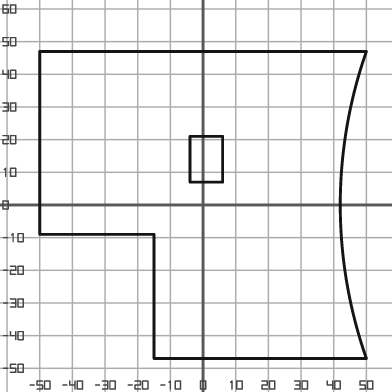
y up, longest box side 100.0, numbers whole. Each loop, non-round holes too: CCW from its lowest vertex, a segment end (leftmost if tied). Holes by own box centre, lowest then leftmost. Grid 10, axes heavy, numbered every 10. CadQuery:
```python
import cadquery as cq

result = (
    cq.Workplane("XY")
    .moveTo(-15.0, -47.0)
    .lineTo(50.0, -47.0)
    .threePointArc((42.0, 0.0), (50.0, 47.0))
    .lineTo(-50.0, 47.0)
    .lineTo(-50.0, -9.0)
    .lineTo(-15.0, -9.0)
    .close()
    .moveTo(-4.0, 7.0)
    .lineTo(6.0, 7.0)
    .lineTo(6.0, 21.0)
    .lineTo(-4.0, 21.0)
    .close()
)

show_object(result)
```